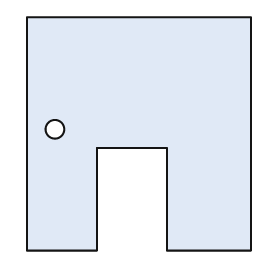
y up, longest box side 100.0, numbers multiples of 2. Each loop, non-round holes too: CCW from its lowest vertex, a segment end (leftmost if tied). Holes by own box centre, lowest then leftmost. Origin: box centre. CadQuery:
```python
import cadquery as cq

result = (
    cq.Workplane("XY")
    .moveTo(-48.0, -50.0)
    .lineTo(-18.0, -50.0)
    .lineTo(-18.0, -6.0)
    .lineTo(12.0, -6.0)
    .lineTo(12.0, -50.0)
    .lineTo(48.0, -50.0)
    .lineTo(48.0, 50.0)
    .lineTo(-48.0, 50.0)
    .close()
    .moveTo(-36.0, 2.0)
    .circle(4.0)
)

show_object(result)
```